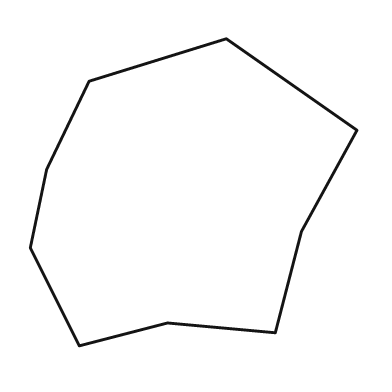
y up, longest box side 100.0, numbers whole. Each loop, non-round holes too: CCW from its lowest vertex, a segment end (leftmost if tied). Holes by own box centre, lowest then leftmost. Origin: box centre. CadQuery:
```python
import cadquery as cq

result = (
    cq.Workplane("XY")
    .moveTo(-35.0, -47.0)
    .lineTo(-8.0, -40.0)
    .lineTo(25.0, -43.0)
    .lineTo(33.0, -12.0)
    .lineTo(50.0, 19.0)
    .lineTo(10.0, 47.0)
    .lineTo(-32.0, 34.0)
    .lineTo(-45.0, 7.0)
    .lineTo(-50.0, -17.0)
    .close()
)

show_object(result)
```